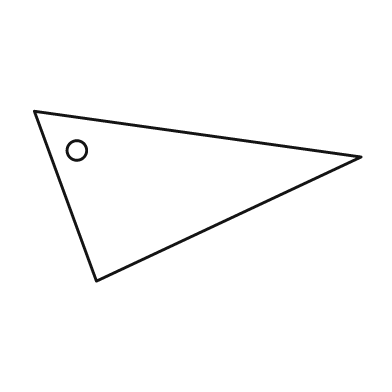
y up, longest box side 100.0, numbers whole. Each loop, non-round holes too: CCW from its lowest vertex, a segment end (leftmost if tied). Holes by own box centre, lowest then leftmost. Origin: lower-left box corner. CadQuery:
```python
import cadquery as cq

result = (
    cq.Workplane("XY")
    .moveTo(19.0, 0.0)
    .lineTo(100.0, 38.0)
    .lineTo(0.0, 52.0)
    .close()
    .moveTo(13.0, 40.0)
    .circle(3.0)
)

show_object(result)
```